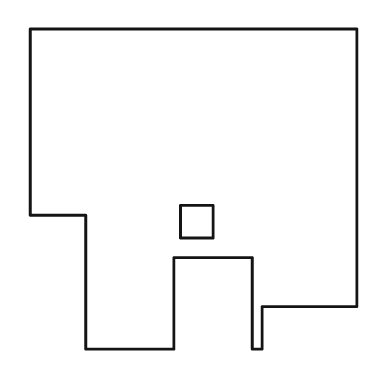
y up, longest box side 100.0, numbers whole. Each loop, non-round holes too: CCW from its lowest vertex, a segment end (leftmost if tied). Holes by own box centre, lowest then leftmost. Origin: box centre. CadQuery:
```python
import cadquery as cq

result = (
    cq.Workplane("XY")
    .moveTo(-33.0, -49.0)
    .lineTo(-6.0, -49.0)
    .lineTo(-6.0, -21.0)
    .lineTo(18.0, -21.0)
    .lineTo(18.0, -49.0)
    .lineTo(21.0, -49.0)
    .lineTo(21.0, -36.0)
    .lineTo(50.0, -36.0)
    .lineTo(50.0, 49.0)
    .lineTo(-50.0, 49.0)
    .lineTo(-50.0, -8.0)
    .lineTo(-33.0, -8.0)
    .close()
    .moveTo(-4.0, -15.0)
    .lineTo(6.0, -15.0)
    .lineTo(6.0, -5.0)
    .lineTo(-4.0, -5.0)
    .close()
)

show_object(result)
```